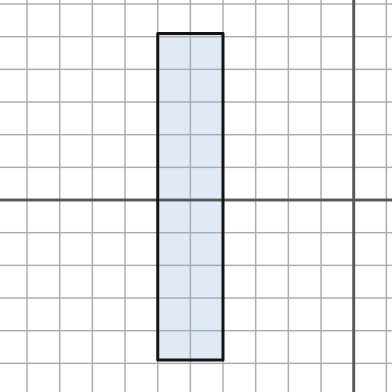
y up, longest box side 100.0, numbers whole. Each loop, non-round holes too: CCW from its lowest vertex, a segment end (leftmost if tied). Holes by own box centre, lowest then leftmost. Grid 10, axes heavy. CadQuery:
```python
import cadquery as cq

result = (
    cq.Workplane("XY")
    .moveTo(-60.0, -49.0)
    .lineTo(-40.0, -49.0)
    .lineTo(-40.0, 51.0)
    .lineTo(-60.0, 51.0)
    .close()
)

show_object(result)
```